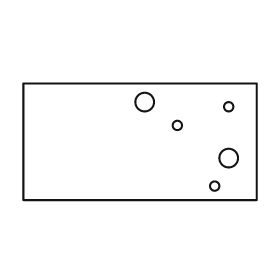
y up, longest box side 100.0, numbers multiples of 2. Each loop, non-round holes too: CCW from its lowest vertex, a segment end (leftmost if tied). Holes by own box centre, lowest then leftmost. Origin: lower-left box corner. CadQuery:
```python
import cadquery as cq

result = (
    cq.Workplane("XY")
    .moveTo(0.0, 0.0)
    .lineTo(100.0, 0.0)
    .lineTo(100.0, 50.0)
    .lineTo(0.0, 50.0)
    .close()
    .moveTo(82.0, 6.0)
    .circle(2.0)
    .moveTo(88.0, 18.0)
    .circle(4.0)
    .moveTo(66.0, 32.0)
    .circle(2.0)
    .moveTo(88.0, 40.0)
    .circle(2.0)
    .moveTo(52.0, 42.0)
    .circle(4.0)
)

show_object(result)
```